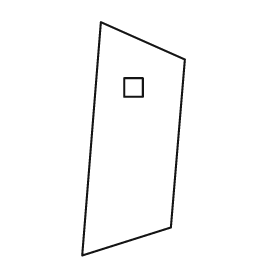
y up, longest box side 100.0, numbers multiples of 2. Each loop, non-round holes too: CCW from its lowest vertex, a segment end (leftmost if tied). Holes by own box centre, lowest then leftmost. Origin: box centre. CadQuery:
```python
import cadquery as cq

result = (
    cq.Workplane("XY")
    .moveTo(-22.0, -50.0)
    .lineTo(16.0, -38.0)
    .lineTo(22.0, 34.0)
    .lineTo(-14.0, 50.0)
    .close()
    .moveTo(-4.0, 18.0)
    .lineTo(4.0, 18.0)
    .lineTo(4.0, 26.0)
    .lineTo(-4.0, 26.0)
    .close()
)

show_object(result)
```